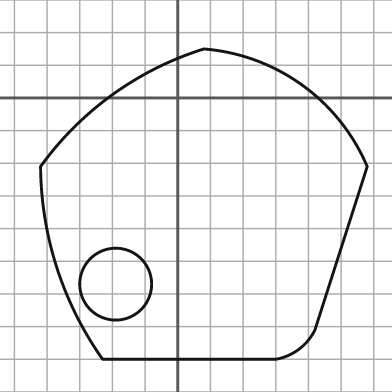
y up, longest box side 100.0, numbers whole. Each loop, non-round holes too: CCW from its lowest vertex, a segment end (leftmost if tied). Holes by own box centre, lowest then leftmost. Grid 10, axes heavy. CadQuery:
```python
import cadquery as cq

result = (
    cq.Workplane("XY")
    .moveTo(-23.0, -80.0)
    .lineTo(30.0, -80.0)
    .threePointArc((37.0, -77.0), (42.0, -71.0))
    .lineTo(58.0, -21.0)
    .threePointArc((38.0, 4.0), (8.0, 15.0))
    .threePointArc((-20.0, 1.0), (-42.0, -21.0))
    .threePointArc((-37.0, -52.0), (-23.0, -80.0))
    .close()
    .moveTo(-19.0, -57.0)
    .circle(11.0)
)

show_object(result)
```